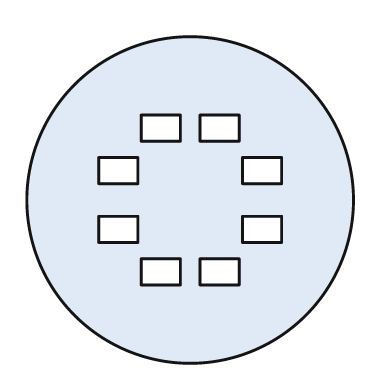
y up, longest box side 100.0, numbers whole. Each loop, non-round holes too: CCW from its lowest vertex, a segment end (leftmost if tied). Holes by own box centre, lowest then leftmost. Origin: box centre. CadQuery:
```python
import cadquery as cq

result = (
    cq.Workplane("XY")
    .moveTo(0.0, 0.0)
    .circle(50.0)
    .moveTo(-15.0, -26.0)
    .lineTo(-3.0, -26.0)
    .lineTo(-3.0, -18.0)
    .lineTo(-15.0, -18.0)
    .close()
    .moveTo(3.0, -26.0)
    .lineTo(15.0, -26.0)
    .lineTo(15.0, -18.0)
    .lineTo(3.0, -18.0)
    .close()
    .moveTo(-28.0, -13.0)
    .lineTo(-16.0, -13.0)
    .lineTo(-16.0, -5.0)
    .lineTo(-28.0, -5.0)
    .close()
    .moveTo(16.0, -13.0)
    .lineTo(28.0, -13.0)
    .lineTo(28.0, -5.0)
    .lineTo(16.0, -5.0)
    .close()
    .moveTo(-28.0, 5.0)
    .lineTo(-16.0, 5.0)
    .lineTo(-16.0, 13.0)
    .lineTo(-28.0, 13.0)
    .close()
    .moveTo(16.0, 5.0)
    .lineTo(28.0, 5.0)
    .lineTo(28.0, 13.0)
    .lineTo(16.0, 13.0)
    .close()
    .moveTo(-15.0, 18.0)
    .lineTo(-3.0, 18.0)
    .lineTo(-3.0, 26.0)
    .lineTo(-15.0, 26.0)
    .close()
    .moveTo(3.0, 18.0)
    .lineTo(15.0, 18.0)
    .lineTo(15.0, 26.0)
    .lineTo(3.0, 26.0)
    .close()
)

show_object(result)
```